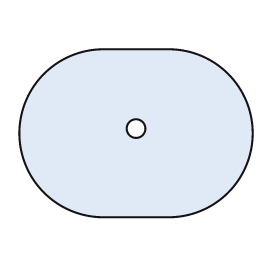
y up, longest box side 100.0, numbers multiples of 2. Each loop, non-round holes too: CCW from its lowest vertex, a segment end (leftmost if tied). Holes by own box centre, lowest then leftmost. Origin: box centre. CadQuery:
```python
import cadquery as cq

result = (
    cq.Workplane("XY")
    .moveTo(-14.0, -36.0)
    .lineTo(14.0, -36.0)
    .threePointArc((50.0, 0.0), (14.0, 36.0))
    .lineTo(-14.0, 36.0)
    .threePointArc((-50.0, 0.0), (-14.0, -36.0))
    .close()
    .moveTo(0.0, 2.0)
    .circle(4.0)
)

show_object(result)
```